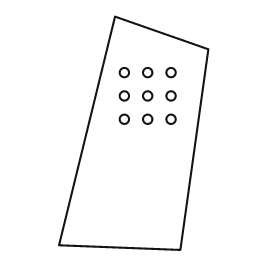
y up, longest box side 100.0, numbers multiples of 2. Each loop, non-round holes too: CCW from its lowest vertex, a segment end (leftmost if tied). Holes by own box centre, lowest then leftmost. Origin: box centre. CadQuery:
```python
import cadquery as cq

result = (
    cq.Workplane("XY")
    .moveTo(20.0, -50.0)
    .lineTo(32.0, 36.0)
    .lineTo(-8.0, 50.0)
    .lineTo(-32.0, -48.0)
    .close()
    .moveTo(-4.0, 6.0)
    .circle(2.0)
    .moveTo(6.0, 6.0)
    .circle(2.0)
    .moveTo(16.0, 6.0)
    .circle(2.0)
    .moveTo(-4.0, 16.0)
    .circle(2.0)
    .moveTo(6.0, 16.0)
    .circle(2.0)
    .moveTo(16.0, 16.0)
    .circle(2.0)
    .moveTo(-4.0, 26.0)
    .circle(2.0)
    .moveTo(6.0, 26.0)
    .circle(2.0)
    .moveTo(16.0, 26.0)
    .circle(2.0)
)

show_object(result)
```